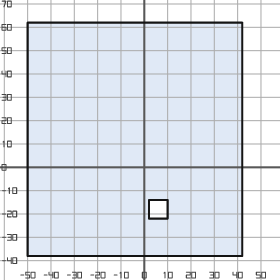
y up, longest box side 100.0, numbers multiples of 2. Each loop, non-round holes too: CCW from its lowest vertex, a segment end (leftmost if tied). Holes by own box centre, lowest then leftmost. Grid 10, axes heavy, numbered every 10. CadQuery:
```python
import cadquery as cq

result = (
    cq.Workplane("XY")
    .moveTo(-50.0, -38.0)
    .lineTo(42.0, -38.0)
    .lineTo(42.0, 62.0)
    .lineTo(-50.0, 62.0)
    .close()
    .moveTo(2.0, -22.0)
    .lineTo(10.0, -22.0)
    .lineTo(10.0, -14.0)
    .lineTo(2.0, -14.0)
    .close()
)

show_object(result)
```